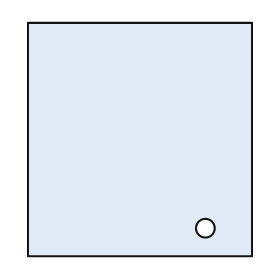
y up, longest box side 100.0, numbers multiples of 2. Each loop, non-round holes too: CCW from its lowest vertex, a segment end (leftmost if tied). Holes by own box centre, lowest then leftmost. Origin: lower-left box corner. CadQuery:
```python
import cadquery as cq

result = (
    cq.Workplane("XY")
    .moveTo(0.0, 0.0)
    .lineTo(96.0, 0.0)
    .lineTo(96.0, 100.0)
    .lineTo(0.0, 100.0)
    .close()
    .moveTo(76.0, 12.0)
    .circle(4.0)
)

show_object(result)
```